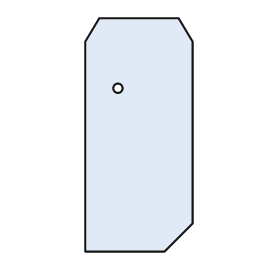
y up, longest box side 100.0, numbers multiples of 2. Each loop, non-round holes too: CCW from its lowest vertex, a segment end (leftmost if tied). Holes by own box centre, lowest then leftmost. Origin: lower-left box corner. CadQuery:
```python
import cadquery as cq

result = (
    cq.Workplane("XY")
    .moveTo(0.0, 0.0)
    .lineTo(34.0, 0.0)
    .lineTo(46.0, 12.0)
    .lineTo(46.0, 90.0)
    .lineTo(40.0, 100.0)
    .lineTo(6.0, 100.0)
    .lineTo(0.0, 90.0)
    .close()
    .moveTo(14.0, 70.0)
    .circle(2.0)
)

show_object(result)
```